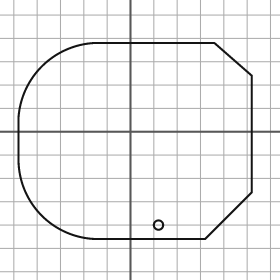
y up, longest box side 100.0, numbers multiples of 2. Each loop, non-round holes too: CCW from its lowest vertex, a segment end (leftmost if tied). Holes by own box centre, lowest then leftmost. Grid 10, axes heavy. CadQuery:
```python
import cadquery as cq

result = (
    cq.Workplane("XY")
    .moveTo(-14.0, -46.0)
    .lineTo(32.0, -46.0)
    .lineTo(52.0, -26.0)
    .lineTo(52.0, 24.0)
    .lineTo(36.0, 38.0)
    .lineTo(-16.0, 38.0)
    .threePointArc((-38.0, 28.0), (-48.0, 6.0))
    .lineTo(-48.0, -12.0)
    .threePointArc((-38.0, -36.0), (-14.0, -46.0))
    .close()
    .moveTo(12.0, -40.0)
    .circle(2.0)
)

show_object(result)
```